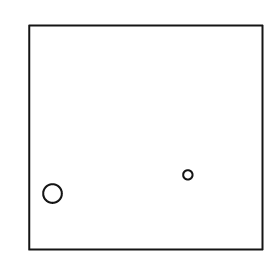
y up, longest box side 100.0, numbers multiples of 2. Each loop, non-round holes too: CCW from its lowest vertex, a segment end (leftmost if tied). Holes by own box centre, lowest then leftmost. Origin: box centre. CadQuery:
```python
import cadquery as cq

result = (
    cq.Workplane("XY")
    .moveTo(-50.0, -48.0)
    .lineTo(50.0, -48.0)
    .lineTo(50.0, 48.0)
    .lineTo(-50.0, 48.0)
    .close()
    .moveTo(-40.0, -24.0)
    .circle(4.0)
    .moveTo(18.0, -16.0)
    .circle(2.0)
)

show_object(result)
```